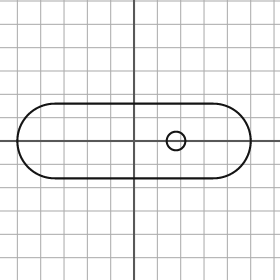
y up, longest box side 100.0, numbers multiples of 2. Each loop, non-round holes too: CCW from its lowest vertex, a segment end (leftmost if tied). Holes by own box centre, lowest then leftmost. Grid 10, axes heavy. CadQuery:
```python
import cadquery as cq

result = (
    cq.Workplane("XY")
    .moveTo(-34.0, -16.0)
    .lineTo(34.0, -16.0)
    .threePointArc((50.0, 0.0), (34.0, 16.0))
    .lineTo(-34.0, 16.0)
    .threePointArc((-50.0, 0.0), (-34.0, -16.0))
    .close()
    .moveTo(18.0, 0.0)
    .circle(4.0)
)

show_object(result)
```